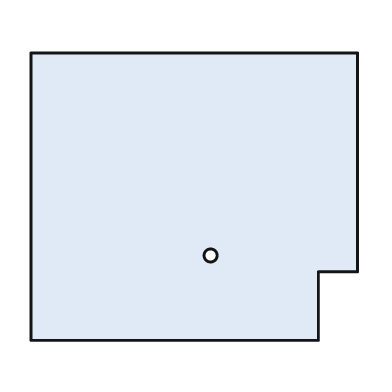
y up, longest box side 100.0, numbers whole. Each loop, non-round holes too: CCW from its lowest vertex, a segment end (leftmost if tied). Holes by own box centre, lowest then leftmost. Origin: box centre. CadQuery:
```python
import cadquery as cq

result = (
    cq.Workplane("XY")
    .moveTo(-50.0, -44.0)
    .lineTo(38.0, -44.0)
    .lineTo(38.0, -23.0)
    .lineTo(50.0, -23.0)
    .lineTo(50.0, 44.0)
    .lineTo(-50.0, 44.0)
    .close()
    .moveTo(5.0, -18.0)
    .circle(2.0)
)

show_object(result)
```